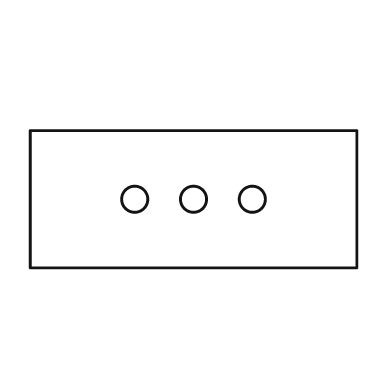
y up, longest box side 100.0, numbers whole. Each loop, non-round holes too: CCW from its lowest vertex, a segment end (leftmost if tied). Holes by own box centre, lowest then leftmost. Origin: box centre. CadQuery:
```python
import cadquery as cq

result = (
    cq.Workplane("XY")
    .moveTo(-50.0, -21.0)
    .lineTo(50.0, -21.0)
    .lineTo(50.0, 21.0)
    .lineTo(-50.0, 21.0)
    .close()
    .moveTo(-18.0, 0.0)
    .circle(4.0)
    .moveTo(0.0, 0.0)
    .circle(4.0)
    .moveTo(18.0, 0.0)
    .circle(4.0)
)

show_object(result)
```